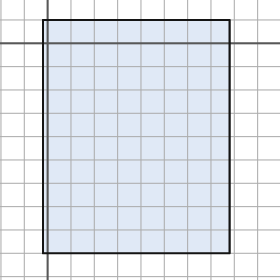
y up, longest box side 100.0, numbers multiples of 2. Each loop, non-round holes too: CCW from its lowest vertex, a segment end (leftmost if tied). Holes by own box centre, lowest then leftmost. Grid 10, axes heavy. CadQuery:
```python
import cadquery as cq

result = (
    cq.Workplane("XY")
    .moveTo(-2.0, -90.0)
    .lineTo(78.0, -90.0)
    .lineTo(78.0, 10.0)
    .lineTo(-2.0, 10.0)
    .close()
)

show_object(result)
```